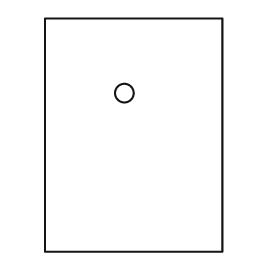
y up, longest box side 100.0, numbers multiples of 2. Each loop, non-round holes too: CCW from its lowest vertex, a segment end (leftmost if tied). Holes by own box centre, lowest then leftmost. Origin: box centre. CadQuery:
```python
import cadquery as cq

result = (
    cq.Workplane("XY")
    .moveTo(-38.0, -50.0)
    .lineTo(38.0, -50.0)
    .lineTo(38.0, 50.0)
    .lineTo(-38.0, 50.0)
    .close()
    .moveTo(-4.0, 18.0)
    .circle(4.0)
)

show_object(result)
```